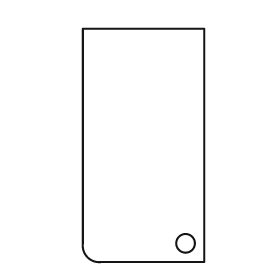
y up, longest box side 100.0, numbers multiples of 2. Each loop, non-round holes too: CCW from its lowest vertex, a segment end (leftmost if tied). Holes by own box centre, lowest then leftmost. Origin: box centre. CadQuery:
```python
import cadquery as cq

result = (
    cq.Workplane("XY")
    .moveTo(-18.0, -50.0)
    .lineTo(26.0, -50.0)
    .lineTo(26.0, 50.0)
    .lineTo(-26.0, 50.0)
    .lineTo(-26.0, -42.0)
    .threePointArc((-24.0, -48.0), (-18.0, -50.0))
    .close()
    .moveTo(18.0, -42.0)
    .circle(4.0)
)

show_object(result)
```